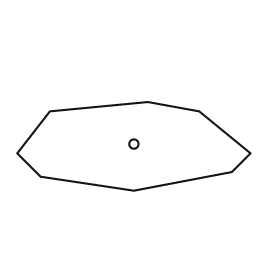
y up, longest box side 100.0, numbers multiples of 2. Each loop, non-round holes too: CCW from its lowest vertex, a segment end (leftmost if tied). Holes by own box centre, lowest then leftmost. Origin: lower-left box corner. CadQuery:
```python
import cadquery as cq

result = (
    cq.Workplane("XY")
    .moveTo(50.0, 0.0)
    .lineTo(92.0, 8.0)
    .lineTo(100.0, 16.0)
    .lineTo(78.0, 34.0)
    .lineTo(56.0, 38.0)
    .lineTo(14.0, 34.0)
    .lineTo(0.0, 16.0)
    .lineTo(10.0, 6.0)
    .close()
    .moveTo(50.0, 20.0)
    .circle(2.0)
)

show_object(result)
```